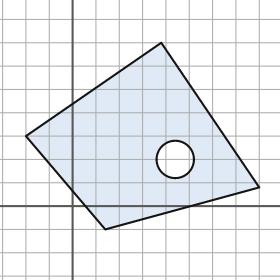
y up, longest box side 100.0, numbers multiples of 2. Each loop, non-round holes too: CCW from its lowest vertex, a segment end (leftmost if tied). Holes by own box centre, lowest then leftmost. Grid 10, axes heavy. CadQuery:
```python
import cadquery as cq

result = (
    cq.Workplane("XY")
    .moveTo(14.0, -10.0)
    .lineTo(80.0, 8.0)
    .lineTo(38.0, 70.0)
    .lineTo(-20.0, 30.0)
    .close()
    .moveTo(44.0, 20.0)
    .circle(8.0)
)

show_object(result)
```